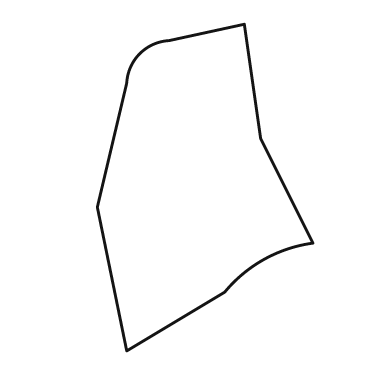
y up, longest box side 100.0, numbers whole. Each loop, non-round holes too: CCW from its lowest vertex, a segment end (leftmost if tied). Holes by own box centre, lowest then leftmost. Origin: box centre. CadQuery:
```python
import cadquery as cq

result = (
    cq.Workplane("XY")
    .moveTo(-24.0, -50.0)
    .lineTo(6.0, -32.0)
    .threePointArc((18.0, -22.0), (33.0, -17.0))
    .lineTo(17.0, 15.0)
    .lineTo(12.0, 50.0)
    .lineTo(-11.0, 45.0)
    .threePointArc((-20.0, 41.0), (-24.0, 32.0))
    .lineTo(-33.0, -6.0)
    .close()
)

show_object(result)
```